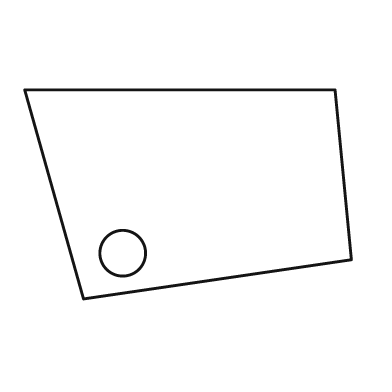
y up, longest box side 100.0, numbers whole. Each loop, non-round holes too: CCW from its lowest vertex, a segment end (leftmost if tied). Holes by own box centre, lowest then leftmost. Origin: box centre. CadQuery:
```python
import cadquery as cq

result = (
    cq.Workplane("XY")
    .moveTo(-32.0, -32.0)
    .lineTo(50.0, -20.0)
    .lineTo(45.0, 32.0)
    .lineTo(-50.0, 32.0)
    .close()
    .moveTo(-20.0, -18.0)
    .circle(7.0)
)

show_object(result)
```